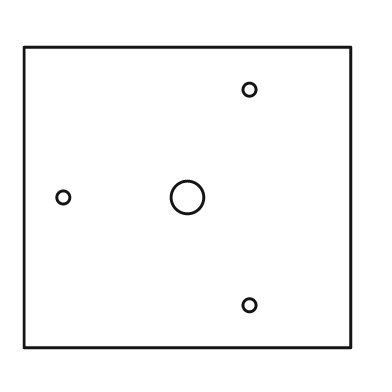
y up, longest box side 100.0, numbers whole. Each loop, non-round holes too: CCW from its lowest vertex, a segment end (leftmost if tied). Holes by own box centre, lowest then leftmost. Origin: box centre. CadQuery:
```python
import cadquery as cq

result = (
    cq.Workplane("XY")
    .moveTo(-50.0, -46.0)
    .lineTo(50.0, -46.0)
    .lineTo(50.0, 46.0)
    .lineTo(-50.0, 46.0)
    .close()
    .moveTo(19.0, -33.0)
    .circle(2.0)
    .moveTo(-38.0, 0.0)
    .circle(2.0)
    .moveTo(0.0, 0.0)
    .circle(5.0)
    .moveTo(19.0, 33.0)
    .circle(2.0)
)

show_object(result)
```